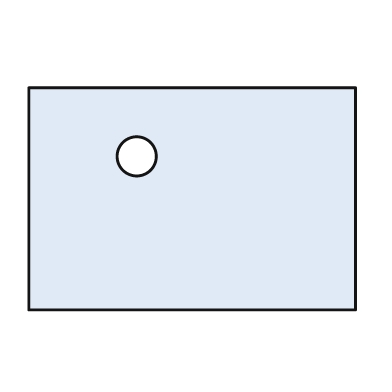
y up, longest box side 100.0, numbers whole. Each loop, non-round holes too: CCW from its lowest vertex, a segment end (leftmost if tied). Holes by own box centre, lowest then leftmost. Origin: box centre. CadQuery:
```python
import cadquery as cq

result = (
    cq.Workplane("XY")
    .moveTo(-50.0, -34.0)
    .lineTo(50.0, -34.0)
    .lineTo(50.0, 34.0)
    .lineTo(-50.0, 34.0)
    .close()
    .moveTo(-17.0, 13.0)
    .circle(6.0)
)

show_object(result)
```